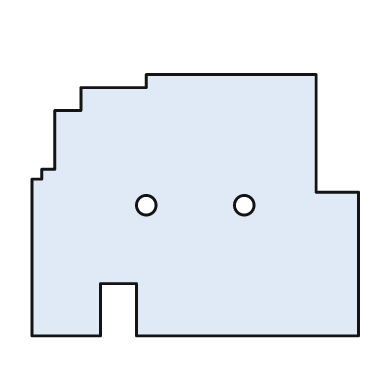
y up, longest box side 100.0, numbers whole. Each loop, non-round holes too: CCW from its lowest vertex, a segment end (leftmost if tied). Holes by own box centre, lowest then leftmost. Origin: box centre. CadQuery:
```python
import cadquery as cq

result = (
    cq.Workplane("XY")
    .moveTo(-50.0, -40.0)
    .lineTo(-29.0, -40.0)
    .lineTo(-29.0, -24.0)
    .lineTo(-18.0, -24.0)
    .lineTo(-18.0, -40.0)
    .lineTo(50.0, -40.0)
    .lineTo(50.0, 4.0)
    .lineTo(37.0, 4.0)
    .lineTo(37.0, 40.0)
    .lineTo(-15.0, 40.0)
    .lineTo(-15.0, 36.0)
    .lineTo(-35.0, 36.0)
    .lineTo(-35.0, 29.0)
    .lineTo(-43.0, 29.0)
    .lineTo(-43.0, 11.0)
    .lineTo(-47.0, 11.0)
    .lineTo(-47.0, 8.0)
    .lineTo(-50.0, 8.0)
    .close()
    .moveTo(-15.0, 0.0)
    .circle(3.0)
    .moveTo(15.0, 0.0)
    .circle(3.0)
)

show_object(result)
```